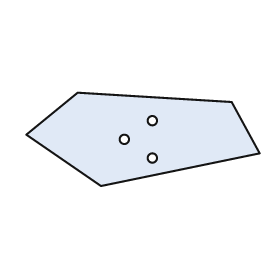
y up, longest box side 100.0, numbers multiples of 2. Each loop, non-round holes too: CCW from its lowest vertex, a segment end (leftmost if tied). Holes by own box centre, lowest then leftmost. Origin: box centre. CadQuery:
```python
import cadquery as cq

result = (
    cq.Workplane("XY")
    .moveTo(-18.0, -20.0)
    .lineTo(50.0, -6.0)
    .lineTo(38.0, 16.0)
    .lineTo(-28.0, 20.0)
    .lineTo(-50.0, 2.0)
    .close()
    .moveTo(4.0, -8.0)
    .circle(2.0)
    .moveTo(-8.0, 0.0)
    .circle(2.0)
    .moveTo(4.0, 8.0)
    .circle(2.0)
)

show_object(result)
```